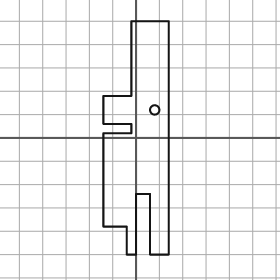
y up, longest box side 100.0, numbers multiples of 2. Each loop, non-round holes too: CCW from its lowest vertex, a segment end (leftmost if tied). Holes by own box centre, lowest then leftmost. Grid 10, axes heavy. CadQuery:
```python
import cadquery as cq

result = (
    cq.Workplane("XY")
    .moveTo(-4.0, -50.0)
    .lineTo(0.0, -50.0)
    .lineTo(0.0, -24.0)
    .lineTo(6.0, -24.0)
    .lineTo(6.0, -50.0)
    .lineTo(14.0, -50.0)
    .lineTo(14.0, 50.0)
    .lineTo(-2.0, 50.0)
    .lineTo(-2.0, 18.0)
    .lineTo(-14.0, 18.0)
    .lineTo(-14.0, 6.0)
    .lineTo(-2.0, 6.0)
    .lineTo(-2.0, 2.0)
    .lineTo(-14.0, 2.0)
    .lineTo(-14.0, -38.0)
    .lineTo(-4.0, -38.0)
    .close()
    .moveTo(8.0, 12.0)
    .circle(2.0)
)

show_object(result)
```